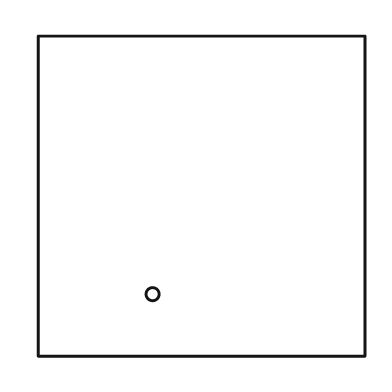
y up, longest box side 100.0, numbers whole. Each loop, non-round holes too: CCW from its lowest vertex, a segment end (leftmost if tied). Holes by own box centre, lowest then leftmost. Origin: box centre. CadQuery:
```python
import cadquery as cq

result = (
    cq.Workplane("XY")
    .moveTo(-50.0, -49.0)
    .lineTo(50.0, -49.0)
    .lineTo(50.0, 49.0)
    .lineTo(-50.0, 49.0)
    .close()
    .moveTo(-15.0, -30.0)
    .circle(2.0)
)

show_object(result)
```